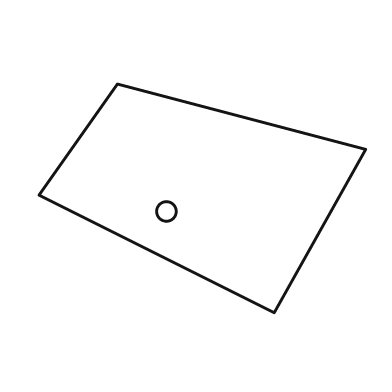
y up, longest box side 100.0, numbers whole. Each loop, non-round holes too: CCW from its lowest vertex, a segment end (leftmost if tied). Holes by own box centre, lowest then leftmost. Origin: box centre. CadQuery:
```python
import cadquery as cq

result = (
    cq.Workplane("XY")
    .moveTo(22.0, -35.0)
    .lineTo(50.0, 15.0)
    .lineTo(-26.0, 35.0)
    .lineTo(-50.0, 1.0)
    .close()
    .moveTo(-11.0, -4.0)
    .circle(3.0)
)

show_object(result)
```